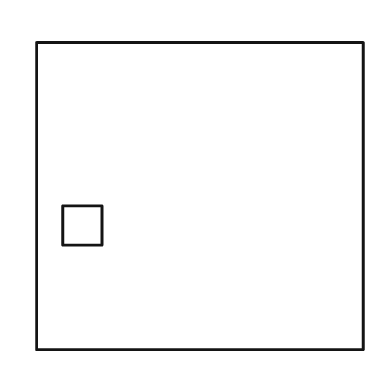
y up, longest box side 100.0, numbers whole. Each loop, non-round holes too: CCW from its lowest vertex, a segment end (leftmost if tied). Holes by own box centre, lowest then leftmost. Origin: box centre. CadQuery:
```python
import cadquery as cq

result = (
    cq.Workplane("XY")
    .moveTo(-50.0, -47.0)
    .lineTo(50.0, -47.0)
    .lineTo(50.0, 47.0)
    .lineTo(-50.0, 47.0)
    .close()
    .moveTo(-42.0, -15.0)
    .lineTo(-30.0, -15.0)
    .lineTo(-30.0, -3.0)
    .lineTo(-42.0, -3.0)
    .close()
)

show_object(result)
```